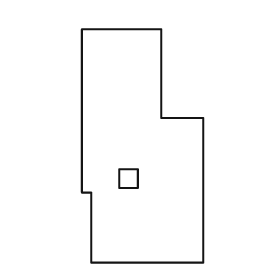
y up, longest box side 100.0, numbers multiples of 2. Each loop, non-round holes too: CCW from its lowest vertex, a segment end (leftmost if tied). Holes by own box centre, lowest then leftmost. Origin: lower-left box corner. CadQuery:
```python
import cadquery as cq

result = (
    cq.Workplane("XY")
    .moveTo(4.0, 0.0)
    .lineTo(52.0, 0.0)
    .lineTo(52.0, 62.0)
    .lineTo(34.0, 62.0)
    .lineTo(34.0, 100.0)
    .lineTo(0.0, 100.0)
    .lineTo(0.0, 30.0)
    .lineTo(4.0, 30.0)
    .close()
    .moveTo(16.0, 32.0)
    .lineTo(24.0, 32.0)
    .lineTo(24.0, 40.0)
    .lineTo(16.0, 40.0)
    .close()
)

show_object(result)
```